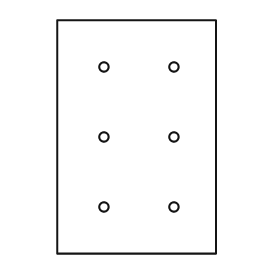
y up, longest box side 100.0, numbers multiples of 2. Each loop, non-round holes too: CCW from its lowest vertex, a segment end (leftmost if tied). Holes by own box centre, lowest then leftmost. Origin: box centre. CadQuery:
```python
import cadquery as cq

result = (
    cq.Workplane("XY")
    .moveTo(-34.0, -50.0)
    .lineTo(34.0, -50.0)
    .lineTo(34.0, 50.0)
    .lineTo(-34.0, 50.0)
    .close()
    .moveTo(-14.0, -30.0)
    .circle(2.0)
    .moveTo(16.0, -30.0)
    .circle(2.0)
    .moveTo(-14.0, 0.0)
    .circle(2.0)
    .moveTo(16.0, 0.0)
    .circle(2.0)
    .moveTo(-14.0, 30.0)
    .circle(2.0)
    .moveTo(16.0, 30.0)
    .circle(2.0)
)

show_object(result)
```